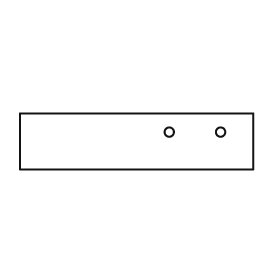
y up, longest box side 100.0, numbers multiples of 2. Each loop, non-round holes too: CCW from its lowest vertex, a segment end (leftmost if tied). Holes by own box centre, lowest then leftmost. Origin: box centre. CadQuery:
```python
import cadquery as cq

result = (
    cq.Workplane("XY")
    .moveTo(-50.0, -12.0)
    .lineTo(50.0, -12.0)
    .lineTo(50.0, 12.0)
    .lineTo(-50.0, 12.0)
    .close()
    .moveTo(14.0, 4.0)
    .circle(2.0)
    .moveTo(36.0, 4.0)
    .circle(2.0)
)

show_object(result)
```